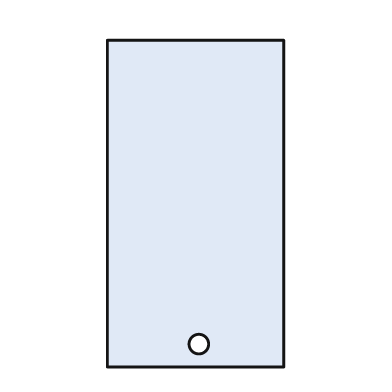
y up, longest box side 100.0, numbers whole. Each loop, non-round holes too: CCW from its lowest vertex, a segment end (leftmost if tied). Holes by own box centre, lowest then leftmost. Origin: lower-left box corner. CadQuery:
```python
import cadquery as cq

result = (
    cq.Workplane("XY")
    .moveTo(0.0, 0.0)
    .lineTo(54.0, 0.0)
    .lineTo(54.0, 100.0)
    .lineTo(0.0, 100.0)
    .close()
    .moveTo(28.0, 7.0)
    .circle(3.0)
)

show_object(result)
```